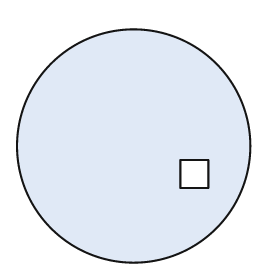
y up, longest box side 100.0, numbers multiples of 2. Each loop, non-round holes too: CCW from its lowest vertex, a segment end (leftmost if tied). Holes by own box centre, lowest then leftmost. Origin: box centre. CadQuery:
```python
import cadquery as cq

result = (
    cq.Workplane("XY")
    .moveTo(0.0, 0.0)
    .circle(50.0)
    .moveTo(20.0, -18.0)
    .lineTo(32.0, -18.0)
    .lineTo(32.0, -6.0)
    .lineTo(20.0, -6.0)
    .close()
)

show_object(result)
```